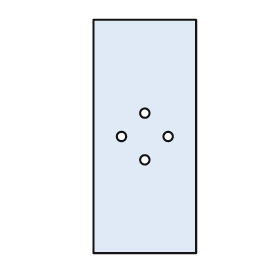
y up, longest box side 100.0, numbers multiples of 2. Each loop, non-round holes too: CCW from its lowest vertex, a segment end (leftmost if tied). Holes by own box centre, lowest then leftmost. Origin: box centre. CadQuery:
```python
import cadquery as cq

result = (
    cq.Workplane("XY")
    .moveTo(-22.0, -50.0)
    .lineTo(22.0, -50.0)
    .lineTo(22.0, 50.0)
    .lineTo(-22.0, 50.0)
    .close()
    .moveTo(0.0, -10.0)
    .circle(2.0)
    .moveTo(-10.0, 0.0)
    .circle(2.0)
    .moveTo(10.0, 0.0)
    .circle(2.0)
    .moveTo(0.0, 10.0)
    .circle(2.0)
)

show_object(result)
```